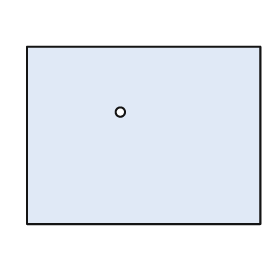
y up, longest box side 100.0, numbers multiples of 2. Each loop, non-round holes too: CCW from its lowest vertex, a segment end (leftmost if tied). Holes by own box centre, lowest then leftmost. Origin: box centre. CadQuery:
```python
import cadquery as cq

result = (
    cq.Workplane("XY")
    .moveTo(-50.0, -38.0)
    .lineTo(50.0, -38.0)
    .lineTo(50.0, 38.0)
    .lineTo(-50.0, 38.0)
    .close()
    .moveTo(-10.0, 10.0)
    .circle(2.0)
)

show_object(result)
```